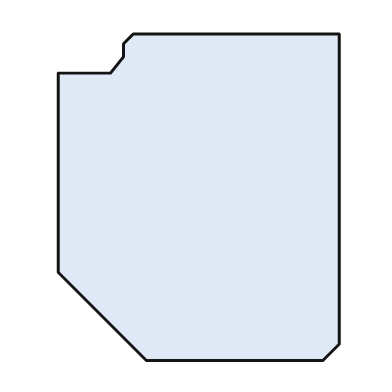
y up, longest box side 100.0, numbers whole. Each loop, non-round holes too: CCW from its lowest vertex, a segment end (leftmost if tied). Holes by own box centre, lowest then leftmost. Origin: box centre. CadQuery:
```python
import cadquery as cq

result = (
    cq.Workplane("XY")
    .moveTo(-16.0, -50.0)
    .lineTo(38.0, -50.0)
    .lineTo(43.0, -45.0)
    .lineTo(43.0, 50.0)
    .lineTo(-20.0, 50.0)
    .lineTo(-23.0, 47.0)
    .lineTo(-23.0, 43.0)
    .lineTo(-27.0, 38.0)
    .lineTo(-43.0, 38.0)
    .lineTo(-43.0, -23.0)
    .close()
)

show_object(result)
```